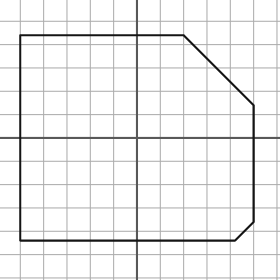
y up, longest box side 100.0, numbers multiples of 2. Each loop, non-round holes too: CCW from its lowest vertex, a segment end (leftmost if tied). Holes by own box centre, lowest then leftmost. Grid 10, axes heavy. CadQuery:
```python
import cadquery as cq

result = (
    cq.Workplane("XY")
    .moveTo(-50.0, -44.0)
    .lineTo(42.0, -44.0)
    .lineTo(50.0, -36.0)
    .lineTo(50.0, 14.0)
    .lineTo(20.0, 44.0)
    .lineTo(-50.0, 44.0)
    .close()
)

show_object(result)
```